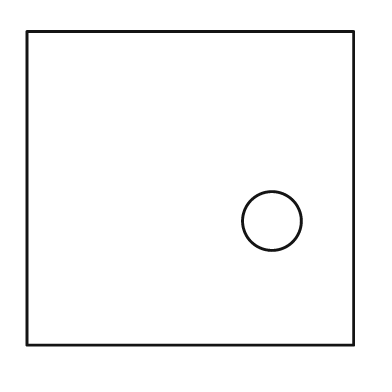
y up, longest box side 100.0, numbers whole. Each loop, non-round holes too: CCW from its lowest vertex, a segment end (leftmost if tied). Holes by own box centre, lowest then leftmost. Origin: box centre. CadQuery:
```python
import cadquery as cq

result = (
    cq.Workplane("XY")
    .moveTo(-50.0, -48.0)
    .lineTo(50.0, -48.0)
    .lineTo(50.0, 48.0)
    .lineTo(-50.0, 48.0)
    .close()
    .moveTo(25.0, -10.0)
    .circle(9.0)
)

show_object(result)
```